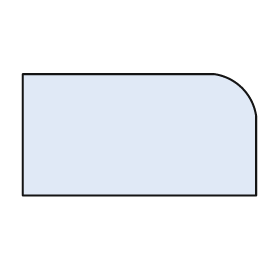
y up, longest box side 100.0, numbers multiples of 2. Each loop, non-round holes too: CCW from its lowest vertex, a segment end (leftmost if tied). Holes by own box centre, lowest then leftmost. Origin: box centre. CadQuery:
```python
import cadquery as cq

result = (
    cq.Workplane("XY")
    .moveTo(-50.0, -26.0)
    .lineTo(50.0, -26.0)
    .lineTo(50.0, 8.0)
    .threePointArc((44.0, 20.0), (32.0, 26.0))
    .lineTo(-50.0, 26.0)
    .close()
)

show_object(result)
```